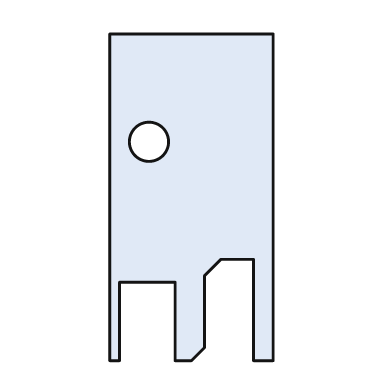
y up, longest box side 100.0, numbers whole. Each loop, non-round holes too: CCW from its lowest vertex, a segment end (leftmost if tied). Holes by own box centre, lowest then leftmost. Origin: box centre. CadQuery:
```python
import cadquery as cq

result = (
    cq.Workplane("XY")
    .moveTo(-25.0, -50.0)
    .lineTo(-22.0, -50.0)
    .lineTo(-22.0, -26.0)
    .lineTo(-5.0, -26.0)
    .lineTo(-5.0, -50.0)
    .lineTo(0.0, -50.0)
    .lineTo(4.0, -46.0)
    .lineTo(4.0, -24.0)
    .lineTo(9.0, -19.0)
    .lineTo(19.0, -19.0)
    .lineTo(19.0, -50.0)
    .lineTo(25.0, -50.0)
    .lineTo(25.0, 50.0)
    .lineTo(-25.0, 50.0)
    .close()
    .moveTo(-13.0, 17.0)
    .circle(6.0)
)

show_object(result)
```